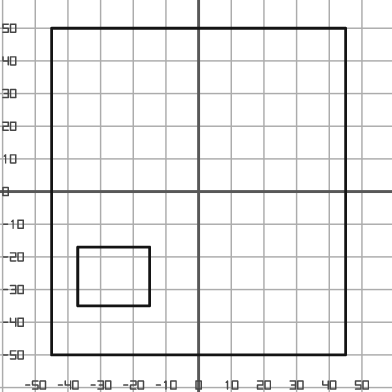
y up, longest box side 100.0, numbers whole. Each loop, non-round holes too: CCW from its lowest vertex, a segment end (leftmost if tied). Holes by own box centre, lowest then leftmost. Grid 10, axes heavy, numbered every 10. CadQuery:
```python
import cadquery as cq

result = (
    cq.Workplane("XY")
    .moveTo(-45.0, -50.0)
    .lineTo(45.0, -50.0)
    .lineTo(45.0, 50.0)
    .lineTo(-45.0, 50.0)
    .close()
    .moveTo(-37.0, -35.0)
    .lineTo(-15.0, -35.0)
    .lineTo(-15.0, -17.0)
    .lineTo(-37.0, -17.0)
    .close()
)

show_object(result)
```